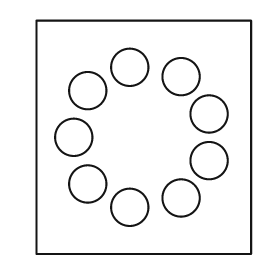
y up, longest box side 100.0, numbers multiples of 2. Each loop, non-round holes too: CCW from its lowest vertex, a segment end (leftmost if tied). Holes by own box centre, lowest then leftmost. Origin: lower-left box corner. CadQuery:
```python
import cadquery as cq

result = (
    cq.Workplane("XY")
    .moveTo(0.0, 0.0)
    .lineTo(92.0, 0.0)
    .lineTo(92.0, 100.0)
    .lineTo(0.0, 100.0)
    .close()
    .moveTo(40.0, 20.0)
    .circle(8.0)
    .moveTo(62.0, 24.0)
    .circle(8.0)
    .moveTo(22.0, 30.0)
    .circle(8.0)
    .moveTo(74.0, 40.0)
    .circle(8.0)
    .moveTo(16.0, 50.0)
    .circle(8.0)
    .moveTo(74.0, 60.0)
    .circle(8.0)
    .moveTo(22.0, 70.0)
    .circle(8.0)
    .moveTo(62.0, 76.0)
    .circle(8.0)
    .moveTo(40.0, 80.0)
    .circle(8.0)
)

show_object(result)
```